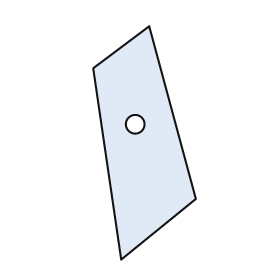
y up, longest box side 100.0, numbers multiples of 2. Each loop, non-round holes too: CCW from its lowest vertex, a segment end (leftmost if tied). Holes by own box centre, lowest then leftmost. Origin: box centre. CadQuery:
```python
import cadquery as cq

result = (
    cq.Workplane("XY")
    .moveTo(-10.0, -50.0)
    .lineTo(22.0, -24.0)
    .lineTo(2.0, 50.0)
    .lineTo(-22.0, 32.0)
    .close()
    .moveTo(-4.0, 8.0)
    .circle(4.0)
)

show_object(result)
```